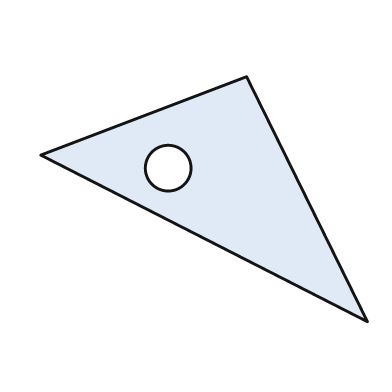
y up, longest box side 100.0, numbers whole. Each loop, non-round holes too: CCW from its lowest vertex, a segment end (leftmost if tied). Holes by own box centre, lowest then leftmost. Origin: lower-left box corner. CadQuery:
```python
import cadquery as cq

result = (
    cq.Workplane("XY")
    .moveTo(100.0, 0.0)
    .lineTo(63.0, 75.0)
    .lineTo(0.0, 51.0)
    .close()
    .moveTo(39.0, 47.0)
    .circle(7.0)
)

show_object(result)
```